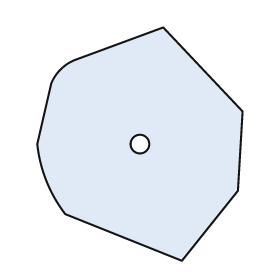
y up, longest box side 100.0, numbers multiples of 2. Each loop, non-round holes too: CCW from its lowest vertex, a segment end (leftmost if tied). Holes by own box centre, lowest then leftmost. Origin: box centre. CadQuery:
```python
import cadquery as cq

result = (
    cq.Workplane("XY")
    .moveTo(18.0, -50.0)
    .lineTo(42.0, -20.0)
    .lineTo(44.0, 14.0)
    .lineTo(10.0, 50.0)
    .lineTo(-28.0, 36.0)
    .threePointArc((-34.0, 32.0), (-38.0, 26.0))
    .lineTo(-44.0, 0.0)
    .threePointArc((-40.0, -16.0), (-32.0, -30.0))
    .close()
    .moveTo(0.0, 0.0)
    .circle(4.0)
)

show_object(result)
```